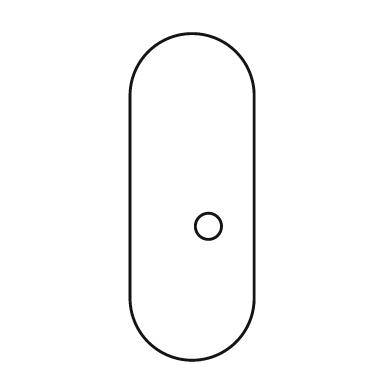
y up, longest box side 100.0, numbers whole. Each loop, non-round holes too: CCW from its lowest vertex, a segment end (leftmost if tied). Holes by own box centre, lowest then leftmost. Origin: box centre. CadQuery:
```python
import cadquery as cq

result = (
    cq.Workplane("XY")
    .moveTo(-19.0, -31.0)
    .threePointArc((0.0, -50.0), (19.0, -31.0))
    .lineTo(19.0, 31.0)
    .threePointArc((0.0, 50.0), (-19.0, 31.0))
    .close()
    .moveTo(5.0, -9.0)
    .circle(4.0)
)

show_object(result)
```